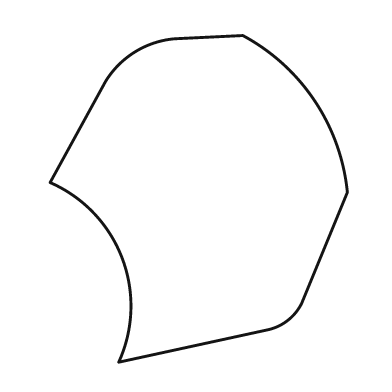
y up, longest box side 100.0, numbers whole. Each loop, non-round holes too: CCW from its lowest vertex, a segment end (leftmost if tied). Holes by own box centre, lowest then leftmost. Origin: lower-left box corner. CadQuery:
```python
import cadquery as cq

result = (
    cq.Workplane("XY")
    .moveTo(21.0, 0.0)
    .lineTo(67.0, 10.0)
    .threePointArc((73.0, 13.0), (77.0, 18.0))
    .lineTo(91.0, 52.0)
    .threePointArc((81.0, 80.0), (59.0, 100.0))
    .lineTo(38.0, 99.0)
    .threePointArc((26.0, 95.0), (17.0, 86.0))
    .lineTo(0.0, 55.0)
    .threePointArc((22.0, 32.0), (21.0, 0.0))
    .close()
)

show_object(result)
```